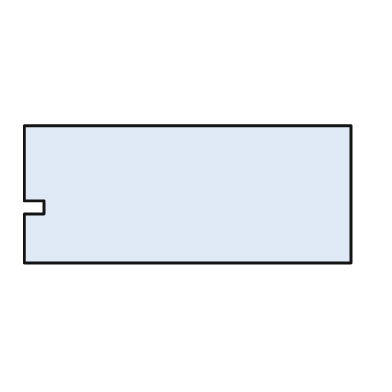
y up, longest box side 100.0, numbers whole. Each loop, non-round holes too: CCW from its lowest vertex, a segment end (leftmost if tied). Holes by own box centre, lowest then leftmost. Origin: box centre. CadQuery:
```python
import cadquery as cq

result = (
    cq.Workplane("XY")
    .moveTo(-50.0, -21.0)
    .lineTo(50.0, -21.0)
    .lineTo(50.0, 21.0)
    .lineTo(-50.0, 21.0)
    .lineTo(-50.0, -2.0)
    .lineTo(-44.0, -2.0)
    .lineTo(-44.0, -6.0)
    .lineTo(-50.0, -6.0)
    .close()
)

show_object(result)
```